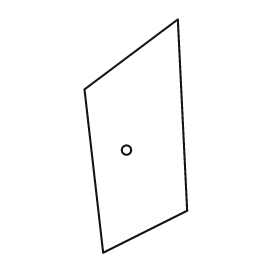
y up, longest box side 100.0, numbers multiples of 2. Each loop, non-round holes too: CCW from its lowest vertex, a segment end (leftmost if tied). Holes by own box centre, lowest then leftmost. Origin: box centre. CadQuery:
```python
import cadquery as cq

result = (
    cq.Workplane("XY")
    .moveTo(-14.0, -50.0)
    .lineTo(22.0, -32.0)
    .lineTo(18.0, 50.0)
    .lineTo(-22.0, 20.0)
    .close()
    .moveTo(-4.0, -6.0)
    .circle(2.0)
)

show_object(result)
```